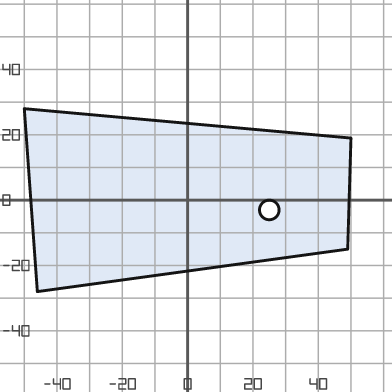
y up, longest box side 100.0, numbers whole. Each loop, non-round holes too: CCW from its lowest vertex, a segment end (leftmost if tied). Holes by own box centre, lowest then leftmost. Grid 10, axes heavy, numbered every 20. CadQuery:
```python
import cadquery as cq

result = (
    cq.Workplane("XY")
    .moveTo(-46.0, -28.0)
    .lineTo(49.0, -15.0)
    .lineTo(50.0, 19.0)
    .lineTo(-50.0, 28.0)
    .close()
    .moveTo(25.0, -3.0)
    .circle(3.0)
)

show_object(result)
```